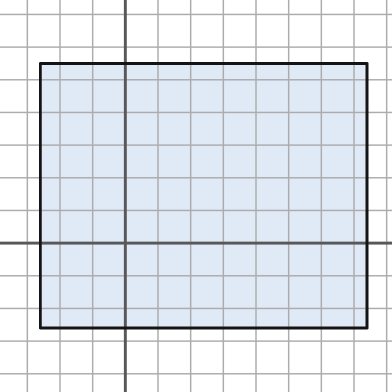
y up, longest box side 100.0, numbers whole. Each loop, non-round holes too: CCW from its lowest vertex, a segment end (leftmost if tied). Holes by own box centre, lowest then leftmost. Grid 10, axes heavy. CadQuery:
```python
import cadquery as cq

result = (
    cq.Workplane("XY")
    .moveTo(-26.0, -26.0)
    .lineTo(74.0, -26.0)
    .lineTo(74.0, 55.0)
    .lineTo(-26.0, 55.0)
    .close()
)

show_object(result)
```